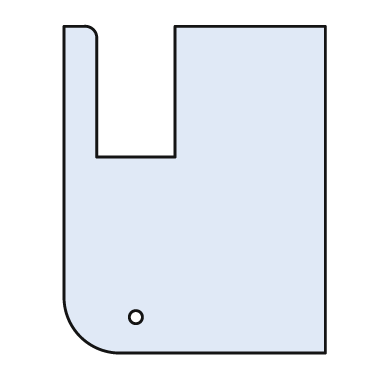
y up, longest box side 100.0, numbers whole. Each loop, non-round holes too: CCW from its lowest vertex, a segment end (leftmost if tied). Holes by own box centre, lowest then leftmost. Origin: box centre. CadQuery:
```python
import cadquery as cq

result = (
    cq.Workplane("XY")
    .moveTo(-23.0, -50.0)
    .lineTo(40.0, -50.0)
    .lineTo(40.0, 50.0)
    .lineTo(-6.0, 50.0)
    .lineTo(-6.0, 10.0)
    .lineTo(-30.0, 10.0)
    .lineTo(-30.0, 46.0)
    .threePointArc((-31.0, 49.0), (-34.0, 50.0))
    .lineTo(-40.0, 50.0)
    .lineTo(-40.0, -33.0)
    .threePointArc((-35.0, -45.0), (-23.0, -50.0))
    .close()
    .moveTo(-18.0, -39.0)
    .circle(2.0)
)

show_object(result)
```